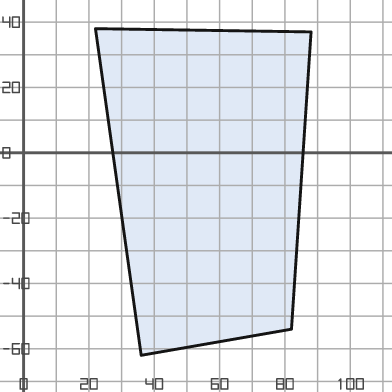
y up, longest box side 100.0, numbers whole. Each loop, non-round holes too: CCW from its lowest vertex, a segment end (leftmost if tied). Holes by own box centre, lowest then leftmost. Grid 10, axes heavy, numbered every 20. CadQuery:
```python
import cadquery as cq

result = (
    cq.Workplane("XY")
    .moveTo(36.0, -62.0)
    .lineTo(82.0, -54.0)
    .lineTo(88.0, 37.0)
    .lineTo(22.0, 38.0)
    .close()
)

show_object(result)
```